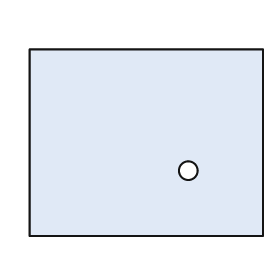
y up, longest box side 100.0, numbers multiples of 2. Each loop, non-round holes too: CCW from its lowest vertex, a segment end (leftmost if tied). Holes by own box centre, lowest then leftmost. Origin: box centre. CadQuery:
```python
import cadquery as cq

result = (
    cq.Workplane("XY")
    .moveTo(-50.0, -40.0)
    .lineTo(50.0, -40.0)
    .lineTo(50.0, 40.0)
    .lineTo(-50.0, 40.0)
    .close()
    .moveTo(18.0, -12.0)
    .circle(4.0)
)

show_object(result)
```